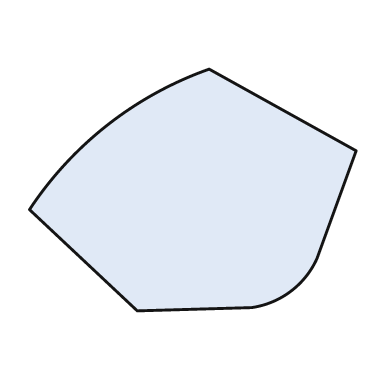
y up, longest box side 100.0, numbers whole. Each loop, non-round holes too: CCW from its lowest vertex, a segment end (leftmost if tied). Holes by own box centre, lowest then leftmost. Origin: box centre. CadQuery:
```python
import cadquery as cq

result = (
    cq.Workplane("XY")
    .moveTo(-17.0, -37.0)
    .lineTo(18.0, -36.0)
    .threePointArc((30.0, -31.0), (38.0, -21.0))
    .lineTo(50.0, 12.0)
    .lineTo(5.0, 37.0)
    .threePointArc((-26.0, 20.0), (-50.0, -6.0))
    .close()
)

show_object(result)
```